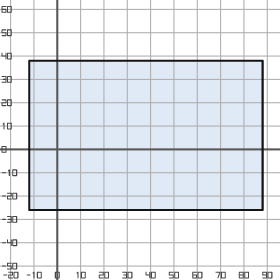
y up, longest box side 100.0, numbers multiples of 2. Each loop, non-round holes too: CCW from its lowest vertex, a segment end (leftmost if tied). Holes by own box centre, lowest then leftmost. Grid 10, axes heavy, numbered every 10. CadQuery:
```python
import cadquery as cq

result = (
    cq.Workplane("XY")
    .moveTo(-12.0, -26.0)
    .lineTo(88.0, -26.0)
    .lineTo(88.0, 38.0)
    .lineTo(-12.0, 38.0)
    .close()
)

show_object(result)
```